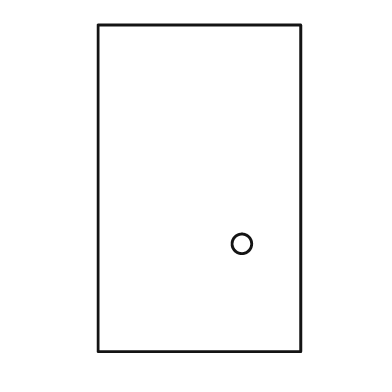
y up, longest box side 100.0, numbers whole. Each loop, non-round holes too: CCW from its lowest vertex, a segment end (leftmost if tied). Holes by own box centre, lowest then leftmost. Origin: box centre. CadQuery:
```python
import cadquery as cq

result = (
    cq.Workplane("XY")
    .moveTo(-31.0, -50.0)
    .lineTo(31.0, -50.0)
    .lineTo(31.0, 50.0)
    .lineTo(-31.0, 50.0)
    .close()
    .moveTo(13.0, -17.0)
    .circle(3.0)
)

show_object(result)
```